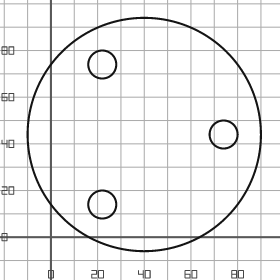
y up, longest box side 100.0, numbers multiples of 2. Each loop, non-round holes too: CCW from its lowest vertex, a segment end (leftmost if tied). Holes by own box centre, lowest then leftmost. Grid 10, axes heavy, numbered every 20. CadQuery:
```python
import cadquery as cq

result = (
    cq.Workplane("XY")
    .moveTo(40.0, 44.0)
    .circle(50.0)
    .moveTo(22.0, 14.0)
    .circle(6.0)
    .moveTo(74.0, 44.0)
    .circle(6.0)
    .moveTo(22.0, 74.0)
    .circle(6.0)
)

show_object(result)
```